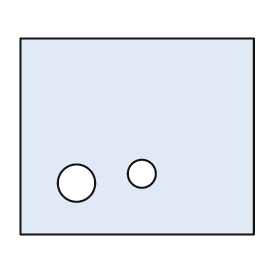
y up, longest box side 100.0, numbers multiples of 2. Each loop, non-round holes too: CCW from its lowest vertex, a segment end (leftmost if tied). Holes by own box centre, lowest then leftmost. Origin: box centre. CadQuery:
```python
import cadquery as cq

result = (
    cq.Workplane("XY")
    .moveTo(-50.0, -42.0)
    .lineTo(50.0, -42.0)
    .lineTo(50.0, 42.0)
    .lineTo(-50.0, 42.0)
    .close()
    .moveTo(-26.0, -20.0)
    .circle(8.0)
    .moveTo(2.0, -16.0)
    .circle(6.0)
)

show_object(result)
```